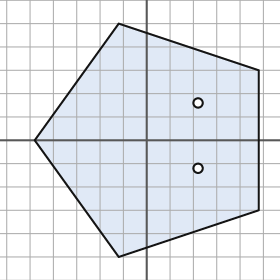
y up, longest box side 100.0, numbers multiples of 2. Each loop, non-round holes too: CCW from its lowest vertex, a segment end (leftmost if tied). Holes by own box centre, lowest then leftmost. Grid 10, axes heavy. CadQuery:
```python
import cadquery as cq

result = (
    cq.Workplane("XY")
    .moveTo(-12.0, -50.0)
    .lineTo(48.0, -30.0)
    .lineTo(48.0, 30.0)
    .lineTo(-12.0, 50.0)
    .lineTo(-48.0, 0.0)
    .close()
    .moveTo(22.0, -12.0)
    .circle(2.0)
    .moveTo(22.0, 16.0)
    .circle(2.0)
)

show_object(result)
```